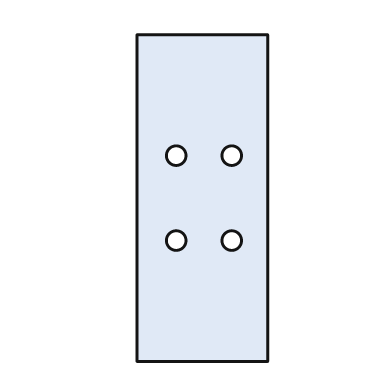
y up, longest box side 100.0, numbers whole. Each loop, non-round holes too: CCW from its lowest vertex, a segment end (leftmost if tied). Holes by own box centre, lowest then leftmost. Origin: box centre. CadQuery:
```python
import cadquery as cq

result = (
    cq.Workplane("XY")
    .moveTo(-20.0, -50.0)
    .lineTo(20.0, -50.0)
    .lineTo(20.0, 50.0)
    .lineTo(-20.0, 50.0)
    .close()
    .moveTo(-8.0, -13.0)
    .circle(3.0)
    .moveTo(9.0, -13.0)
    .circle(3.0)
    .moveTo(-8.0, 13.0)
    .circle(3.0)
    .moveTo(9.0, 13.0)
    .circle(3.0)
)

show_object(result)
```